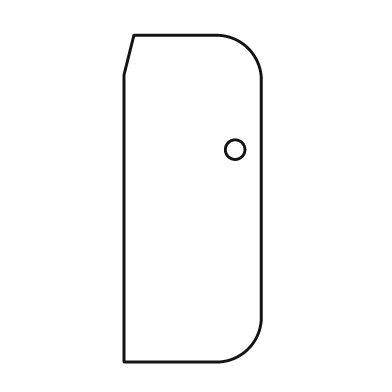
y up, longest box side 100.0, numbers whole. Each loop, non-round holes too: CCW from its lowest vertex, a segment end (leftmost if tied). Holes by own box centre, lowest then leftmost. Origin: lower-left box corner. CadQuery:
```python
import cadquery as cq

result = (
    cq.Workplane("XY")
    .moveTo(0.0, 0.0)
    .lineTo(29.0, 0.0)
    .threePointArc((38.0, 4.0), (42.0, 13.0))
    .lineTo(42.0, 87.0)
    .threePointArc((38.0, 96.0), (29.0, 100.0))
    .lineTo(3.0, 100.0)
    .lineTo(0.0, 88.0)
    .close()
    .moveTo(34.0, 65.0)
    .circle(3.0)
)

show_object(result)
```